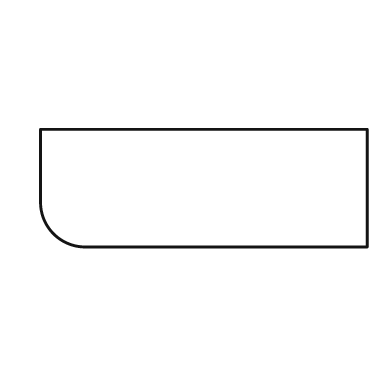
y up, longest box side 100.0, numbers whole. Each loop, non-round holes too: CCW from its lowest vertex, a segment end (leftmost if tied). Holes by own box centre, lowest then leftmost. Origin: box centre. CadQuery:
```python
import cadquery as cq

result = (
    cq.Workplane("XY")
    .moveTo(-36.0, -18.0)
    .lineTo(50.0, -18.0)
    .lineTo(50.0, 18.0)
    .lineTo(-50.0, 18.0)
    .lineTo(-50.0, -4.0)
    .threePointArc((-46.0, -14.0), (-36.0, -18.0))
    .close()
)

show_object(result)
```